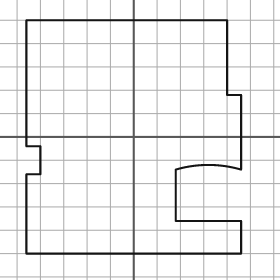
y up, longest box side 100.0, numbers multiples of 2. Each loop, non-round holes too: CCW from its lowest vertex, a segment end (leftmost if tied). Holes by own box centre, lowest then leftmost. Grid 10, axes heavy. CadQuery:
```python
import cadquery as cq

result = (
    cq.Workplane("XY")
    .moveTo(-46.0, -50.0)
    .lineTo(46.0, -50.0)
    .lineTo(46.0, -36.0)
    .lineTo(18.0, -36.0)
    .lineTo(18.0, -14.0)
    .threePointArc((32.0, -12.0), (46.0, -14.0))
    .lineTo(46.0, 18.0)
    .lineTo(40.0, 18.0)
    .lineTo(40.0, 50.0)
    .lineTo(-46.0, 50.0)
    .lineTo(-46.0, -4.0)
    .lineTo(-40.0, -4.0)
    .lineTo(-40.0, -16.0)
    .lineTo(-46.0, -16.0)
    .close()
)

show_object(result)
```